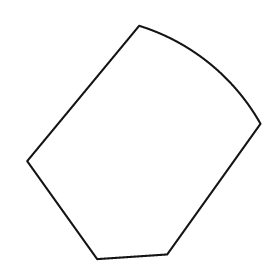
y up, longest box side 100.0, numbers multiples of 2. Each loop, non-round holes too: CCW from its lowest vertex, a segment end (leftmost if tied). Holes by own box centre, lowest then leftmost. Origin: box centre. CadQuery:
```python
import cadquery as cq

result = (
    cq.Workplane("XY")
    .moveTo(-20.0, -50.0)
    .lineTo(10.0, -48.0)
    .lineTo(50.0, 8.0)
    .threePointArc((28.0, 34.0), (-2.0, 50.0))
    .lineTo(-50.0, -8.0)
    .close()
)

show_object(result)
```